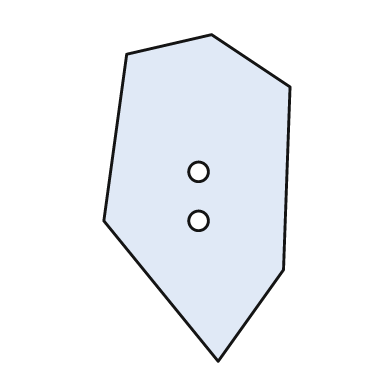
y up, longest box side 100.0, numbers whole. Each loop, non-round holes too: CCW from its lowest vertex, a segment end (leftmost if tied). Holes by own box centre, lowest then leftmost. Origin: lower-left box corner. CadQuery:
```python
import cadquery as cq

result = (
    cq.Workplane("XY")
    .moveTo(35.0, 0.0)
    .lineTo(55.0, 28.0)
    .lineTo(57.0, 84.0)
    .lineTo(33.0, 100.0)
    .lineTo(7.0, 94.0)
    .lineTo(0.0, 43.0)
    .close()
    .moveTo(29.0, 43.0)
    .circle(3.0)
    .moveTo(29.0, 58.0)
    .circle(3.0)
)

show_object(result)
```